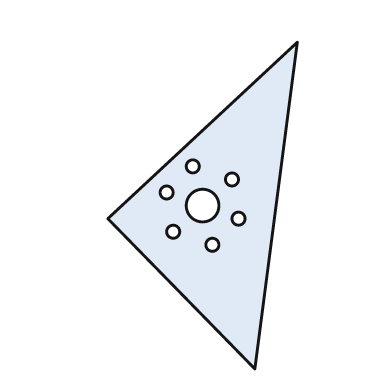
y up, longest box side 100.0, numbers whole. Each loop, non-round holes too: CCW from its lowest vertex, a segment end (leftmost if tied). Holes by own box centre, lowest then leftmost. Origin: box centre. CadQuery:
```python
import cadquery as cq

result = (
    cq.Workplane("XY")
    .moveTo(16.0, -50.0)
    .lineTo(29.0, 50.0)
    .lineTo(-29.0, -4.0)
    .close()
    .moveTo(3.0, -12.0)
    .circle(2.0)
    .moveTo(-9.0, -8.0)
    .circle(2.0)
    .moveTo(11.0, -4.0)
    .circle(2.0)
    .moveTo(0.0, 0.0)
    .circle(5.0)
    .moveTo(-11.0, 4.0)
    .circle(2.0)
    .moveTo(9.0, 8.0)
    .circle(2.0)
    .moveTo(-3.0, 12.0)
    .circle(2.0)
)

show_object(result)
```